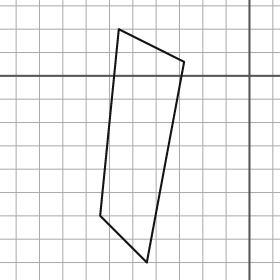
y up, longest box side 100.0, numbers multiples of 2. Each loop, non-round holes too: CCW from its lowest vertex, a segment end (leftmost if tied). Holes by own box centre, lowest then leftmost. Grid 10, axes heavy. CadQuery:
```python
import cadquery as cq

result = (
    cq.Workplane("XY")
    .moveTo(-44.0, -80.0)
    .lineTo(-28.0, 6.0)
    .lineTo(-56.0, 20.0)
    .lineTo(-64.0, -60.0)
    .close()
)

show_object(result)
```